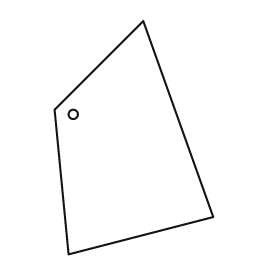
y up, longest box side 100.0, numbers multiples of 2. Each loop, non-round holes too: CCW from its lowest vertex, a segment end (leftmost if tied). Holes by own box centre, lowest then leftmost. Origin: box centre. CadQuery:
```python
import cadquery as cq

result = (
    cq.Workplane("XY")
    .moveTo(-28.0, -50.0)
    .lineTo(34.0, -34.0)
    .lineTo(4.0, 50.0)
    .lineTo(-34.0, 12.0)
    .close()
    .moveTo(-26.0, 10.0)
    .circle(2.0)
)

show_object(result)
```